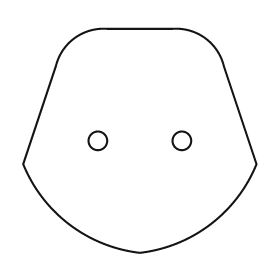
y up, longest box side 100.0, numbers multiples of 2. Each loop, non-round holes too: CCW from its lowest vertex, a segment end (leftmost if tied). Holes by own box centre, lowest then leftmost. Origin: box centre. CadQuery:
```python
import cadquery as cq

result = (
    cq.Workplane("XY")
    .moveTo(0.0, -48.0)
    .threePointArc((30.0, -36.0), (50.0, -10.0))
    .lineTo(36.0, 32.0)
    .threePointArc((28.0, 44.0), (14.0, 48.0))
    .lineTo(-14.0, 48.0)
    .threePointArc((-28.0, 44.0), (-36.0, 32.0))
    .lineTo(-50.0, -10.0)
    .threePointArc((-30.0, -36.0), (0.0, -48.0))
    .close()
    .moveTo(-18.0, 0.0)
    .circle(4.0)
    .moveTo(18.0, 0.0)
    .circle(4.0)
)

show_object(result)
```